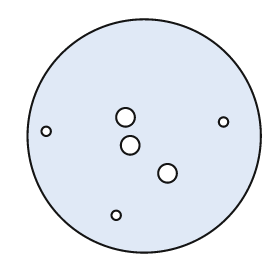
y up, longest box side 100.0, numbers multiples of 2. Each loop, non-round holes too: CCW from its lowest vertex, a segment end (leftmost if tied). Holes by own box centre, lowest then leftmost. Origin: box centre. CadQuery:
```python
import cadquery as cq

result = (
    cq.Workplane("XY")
    .moveTo(0.0, 0.0)
    .circle(50.0)
    .moveTo(-12.0, -34.0)
    .circle(2.0)
    .moveTo(10.0, -16.0)
    .circle(4.0)
    .moveTo(-6.0, -4.0)
    .circle(4.0)
    .moveTo(-42.0, 2.0)
    .circle(2.0)
    .moveTo(34.0, 6.0)
    .circle(2.0)
    .moveTo(-8.0, 8.0)
    .circle(4.0)
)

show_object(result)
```